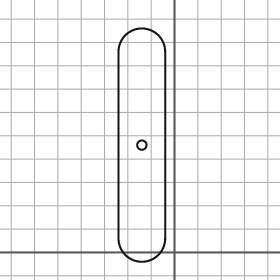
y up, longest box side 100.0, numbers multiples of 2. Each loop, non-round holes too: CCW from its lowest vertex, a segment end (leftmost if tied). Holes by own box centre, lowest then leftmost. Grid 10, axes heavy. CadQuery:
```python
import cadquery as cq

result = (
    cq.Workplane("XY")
    .moveTo(-24.0, 6.0)
    .threePointArc((-14.0, -4.0), (-4.0, 6.0))
    .lineTo(-4.0, 86.0)
    .threePointArc((-14.0, 96.0), (-24.0, 86.0))
    .close()
    .moveTo(-14.0, 46.0)
    .circle(2.0)
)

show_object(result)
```